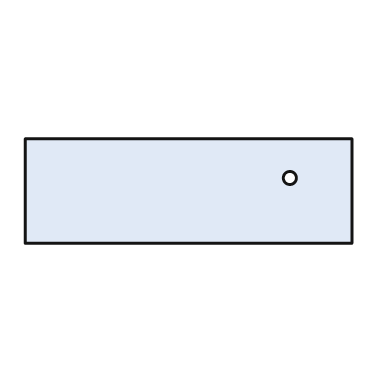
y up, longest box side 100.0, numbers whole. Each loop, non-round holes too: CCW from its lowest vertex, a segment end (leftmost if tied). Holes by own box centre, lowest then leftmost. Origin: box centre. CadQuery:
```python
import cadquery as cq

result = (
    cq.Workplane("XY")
    .moveTo(-50.0, -16.0)
    .lineTo(50.0, -16.0)
    .lineTo(50.0, 16.0)
    .lineTo(-50.0, 16.0)
    .close()
    .moveTo(31.0, 4.0)
    .circle(2.0)
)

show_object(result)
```